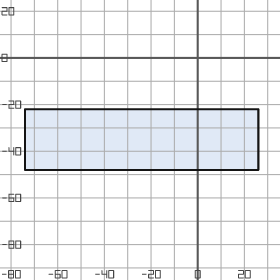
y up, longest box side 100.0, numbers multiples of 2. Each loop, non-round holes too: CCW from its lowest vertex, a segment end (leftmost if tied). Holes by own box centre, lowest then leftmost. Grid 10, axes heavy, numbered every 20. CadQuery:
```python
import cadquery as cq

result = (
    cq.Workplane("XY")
    .moveTo(-74.0, -48.0)
    .lineTo(26.0, -48.0)
    .lineTo(26.0, -22.0)
    .lineTo(-74.0, -22.0)
    .close()
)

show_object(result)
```